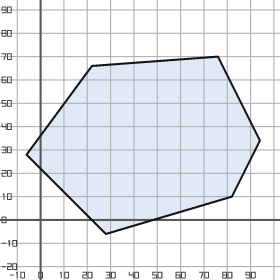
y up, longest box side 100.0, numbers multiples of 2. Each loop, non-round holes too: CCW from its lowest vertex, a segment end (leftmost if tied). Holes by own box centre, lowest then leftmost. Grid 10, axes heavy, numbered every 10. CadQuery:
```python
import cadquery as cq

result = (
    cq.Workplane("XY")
    .moveTo(28.0, -6.0)
    .lineTo(82.0, 10.0)
    .lineTo(94.0, 34.0)
    .lineTo(76.0, 70.0)
    .lineTo(22.0, 66.0)
    .lineTo(-6.0, 28.0)
    .close()
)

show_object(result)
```